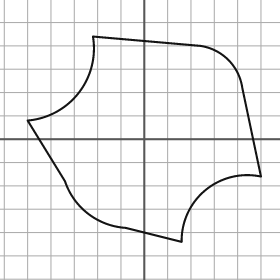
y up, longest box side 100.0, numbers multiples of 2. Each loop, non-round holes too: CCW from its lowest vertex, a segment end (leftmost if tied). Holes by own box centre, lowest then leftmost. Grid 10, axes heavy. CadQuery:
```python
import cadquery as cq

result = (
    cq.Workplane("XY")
    .moveTo(16.0, -44.0)
    .threePointArc((26.0, -22.0), (50.0, -16.0))
    .lineTo(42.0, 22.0)
    .threePointArc((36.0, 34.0), (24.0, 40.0))
    .lineTo(-22.0, 44.0)
    .threePointArc((-28.0, 20.0), (-50.0, 8.0))
    .lineTo(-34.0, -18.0)
    .threePointArc((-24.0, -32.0), (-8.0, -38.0))
    .close()
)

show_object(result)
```